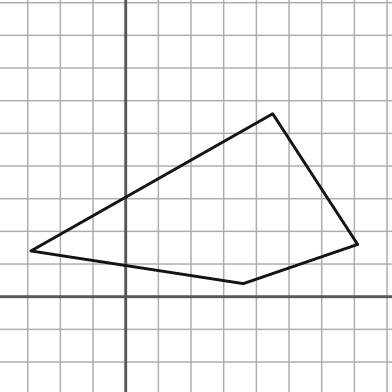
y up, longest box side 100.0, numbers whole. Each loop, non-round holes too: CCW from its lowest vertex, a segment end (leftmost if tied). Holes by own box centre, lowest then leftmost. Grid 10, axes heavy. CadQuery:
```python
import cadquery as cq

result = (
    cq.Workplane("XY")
    .moveTo(36.0, 4.0)
    .lineTo(71.0, 16.0)
    .lineTo(45.0, 56.0)
    .lineTo(-29.0, 14.0)
    .close()
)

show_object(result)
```